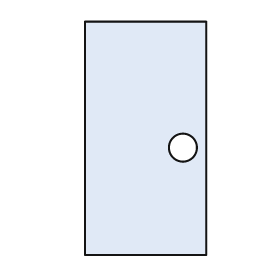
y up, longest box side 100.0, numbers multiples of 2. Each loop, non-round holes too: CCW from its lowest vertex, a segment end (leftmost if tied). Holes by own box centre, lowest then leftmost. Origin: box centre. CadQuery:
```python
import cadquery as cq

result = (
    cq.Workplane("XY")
    .moveTo(-26.0, -50.0)
    .lineTo(26.0, -50.0)
    .lineTo(26.0, 50.0)
    .lineTo(-26.0, 50.0)
    .close()
    .moveTo(16.0, -4.0)
    .circle(6.0)
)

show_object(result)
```